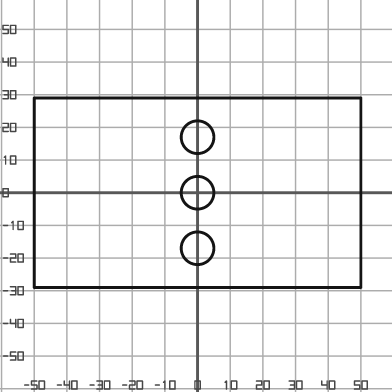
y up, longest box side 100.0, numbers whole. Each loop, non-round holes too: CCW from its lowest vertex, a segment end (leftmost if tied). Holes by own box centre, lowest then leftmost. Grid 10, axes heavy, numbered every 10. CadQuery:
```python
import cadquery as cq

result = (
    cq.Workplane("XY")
    .moveTo(-50.0, -29.0)
    .lineTo(50.0, -29.0)
    .lineTo(50.0, 29.0)
    .lineTo(-50.0, 29.0)
    .close()
    .moveTo(0.0, -17.0)
    .circle(5.0)
    .moveTo(0.0, 0.0)
    .circle(5.0)
    .moveTo(0.0, 17.0)
    .circle(5.0)
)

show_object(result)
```